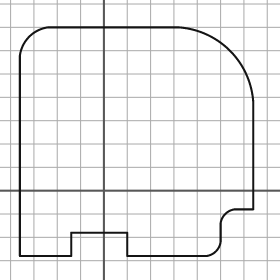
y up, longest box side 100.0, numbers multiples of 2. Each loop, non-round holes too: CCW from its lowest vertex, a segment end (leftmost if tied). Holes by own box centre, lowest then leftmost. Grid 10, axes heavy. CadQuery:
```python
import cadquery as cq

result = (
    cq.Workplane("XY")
    .moveTo(-36.0, -28.0)
    .lineTo(-14.0, -28.0)
    .lineTo(-14.0, -18.0)
    .lineTo(10.0, -18.0)
    .lineTo(10.0, -28.0)
    .lineTo(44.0, -28.0)
    .threePointArc((48.0, -26.0), (50.0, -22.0))
    .lineTo(50.0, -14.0)
    .threePointArc((52.0, -10.0), (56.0, -8.0))
    .lineTo(64.0, -8.0)
    .lineTo(64.0, 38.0)
    .threePointArc((54.0, 60.0), (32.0, 70.0))
    .lineTo(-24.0, 70.0)
    .threePointArc((-32.0, 66.0), (-36.0, 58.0))
    .close()
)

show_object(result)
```